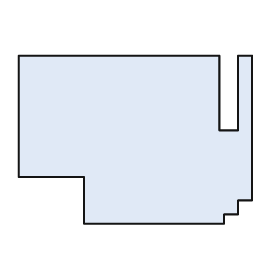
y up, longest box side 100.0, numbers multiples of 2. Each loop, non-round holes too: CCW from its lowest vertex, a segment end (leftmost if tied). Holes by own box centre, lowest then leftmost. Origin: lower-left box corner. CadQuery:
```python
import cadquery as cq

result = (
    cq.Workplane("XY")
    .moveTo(28.0, 0.0)
    .lineTo(88.0, 0.0)
    .lineTo(88.0, 4.0)
    .lineTo(94.0, 4.0)
    .lineTo(94.0, 10.0)
    .lineTo(100.0, 10.0)
    .lineTo(100.0, 72.0)
    .lineTo(94.0, 72.0)
    .lineTo(94.0, 40.0)
    .lineTo(86.0, 40.0)
    .lineTo(86.0, 72.0)
    .lineTo(0.0, 72.0)
    .lineTo(0.0, 20.0)
    .lineTo(28.0, 20.0)
    .close()
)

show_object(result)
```